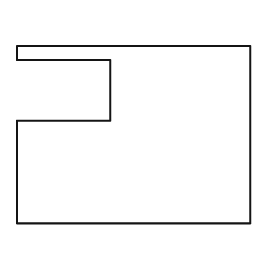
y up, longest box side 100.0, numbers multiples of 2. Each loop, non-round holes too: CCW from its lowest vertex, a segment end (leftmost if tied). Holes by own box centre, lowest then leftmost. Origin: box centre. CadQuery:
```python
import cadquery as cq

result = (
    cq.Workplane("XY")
    .moveTo(-50.0, -38.0)
    .lineTo(50.0, -38.0)
    .lineTo(50.0, 38.0)
    .lineTo(-50.0, 38.0)
    .lineTo(-50.0, 32.0)
    .lineTo(-10.0, 32.0)
    .lineTo(-10.0, 6.0)
    .lineTo(-50.0, 6.0)
    .close()
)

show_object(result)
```